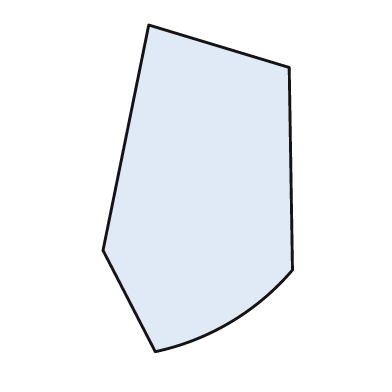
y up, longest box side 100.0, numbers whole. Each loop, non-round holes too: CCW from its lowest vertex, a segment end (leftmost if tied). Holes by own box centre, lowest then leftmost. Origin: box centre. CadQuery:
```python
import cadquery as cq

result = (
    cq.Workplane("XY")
    .moveTo(-13.0, -50.0)
    .threePointArc((10.0, -41.0), (29.0, -25.0))
    .lineTo(28.0, 37.0)
    .lineTo(-15.0, 50.0)
    .lineTo(-29.0, -19.0)
    .close()
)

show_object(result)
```